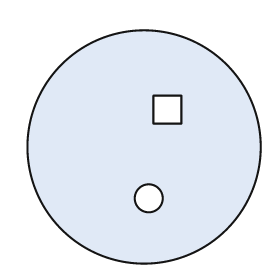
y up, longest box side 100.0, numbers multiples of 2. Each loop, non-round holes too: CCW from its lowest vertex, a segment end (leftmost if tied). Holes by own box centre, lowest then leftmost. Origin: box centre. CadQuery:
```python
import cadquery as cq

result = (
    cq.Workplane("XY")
    .moveTo(0.0, 0.0)
    .circle(50.0)
    .moveTo(2.0, -22.0)
    .circle(6.0)
    .moveTo(4.0, 10.0)
    .lineTo(16.0, 10.0)
    .lineTo(16.0, 22.0)
    .lineTo(4.0, 22.0)
    .close()
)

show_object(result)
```